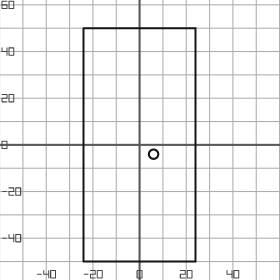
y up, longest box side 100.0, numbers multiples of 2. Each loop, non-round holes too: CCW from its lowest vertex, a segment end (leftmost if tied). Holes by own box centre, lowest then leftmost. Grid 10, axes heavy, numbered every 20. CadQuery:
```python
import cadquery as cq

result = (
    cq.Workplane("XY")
    .moveTo(-24.0, -50.0)
    .lineTo(24.0, -50.0)
    .lineTo(24.0, 50.0)
    .lineTo(-24.0, 50.0)
    .close()
    .moveTo(6.0, -4.0)
    .circle(2.0)
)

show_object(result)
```